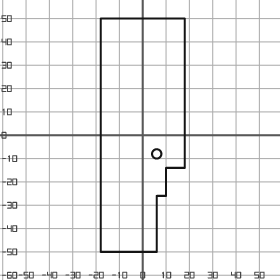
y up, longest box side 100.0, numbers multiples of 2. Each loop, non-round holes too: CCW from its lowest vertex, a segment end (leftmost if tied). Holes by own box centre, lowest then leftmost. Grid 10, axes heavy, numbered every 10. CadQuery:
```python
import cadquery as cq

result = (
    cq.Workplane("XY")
    .moveTo(-18.0, -50.0)
    .lineTo(6.0, -50.0)
    .lineTo(6.0, -26.0)
    .lineTo(10.0, -26.0)
    .lineTo(10.0, -14.0)
    .lineTo(18.0, -14.0)
    .lineTo(18.0, 50.0)
    .lineTo(-18.0, 50.0)
    .close()
    .moveTo(6.0, -8.0)
    .circle(2.0)
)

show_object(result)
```